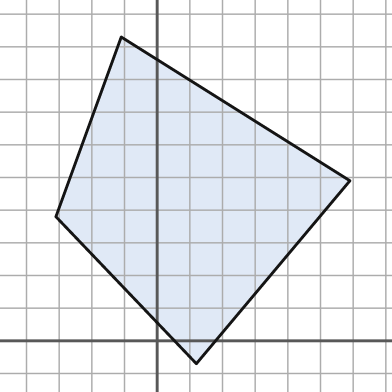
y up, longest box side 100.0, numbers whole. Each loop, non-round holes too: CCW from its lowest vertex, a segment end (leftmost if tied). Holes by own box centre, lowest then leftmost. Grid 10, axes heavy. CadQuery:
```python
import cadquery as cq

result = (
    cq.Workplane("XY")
    .moveTo(12.0, -7.0)
    .lineTo(59.0, 49.0)
    .lineTo(-11.0, 93.0)
    .lineTo(-31.0, 38.0)
    .close()
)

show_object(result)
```